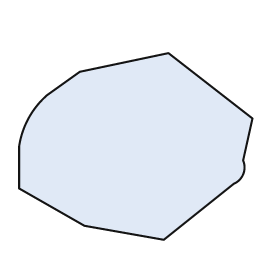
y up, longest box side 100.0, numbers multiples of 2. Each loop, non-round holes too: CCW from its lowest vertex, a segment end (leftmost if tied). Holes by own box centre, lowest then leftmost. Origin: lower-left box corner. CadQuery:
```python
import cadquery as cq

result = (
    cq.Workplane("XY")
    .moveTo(62.0, 0.0)
    .lineTo(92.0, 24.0)
    .threePointArc((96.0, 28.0), (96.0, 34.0))
    .lineTo(100.0, 52.0)
    .lineTo(64.0, 80.0)
    .lineTo(26.0, 72.0)
    .lineTo(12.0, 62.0)
    .threePointArc((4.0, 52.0), (0.0, 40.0))
    .lineTo(0.0, 22.0)
    .lineTo(28.0, 6.0)
    .close()
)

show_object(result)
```